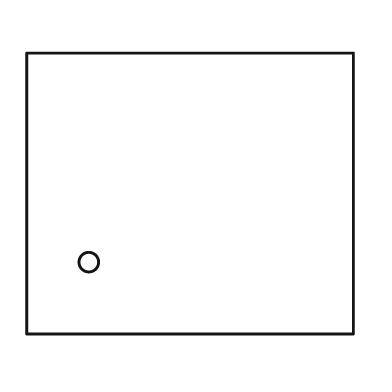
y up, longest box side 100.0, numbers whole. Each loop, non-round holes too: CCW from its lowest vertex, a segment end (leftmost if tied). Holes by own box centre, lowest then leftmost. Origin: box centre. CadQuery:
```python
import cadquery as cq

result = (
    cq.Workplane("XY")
    .moveTo(-50.0, -43.0)
    .lineTo(50.0, -43.0)
    .lineTo(50.0, 43.0)
    .lineTo(-50.0, 43.0)
    .close()
    .moveTo(-31.0, -21.0)
    .circle(3.0)
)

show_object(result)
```